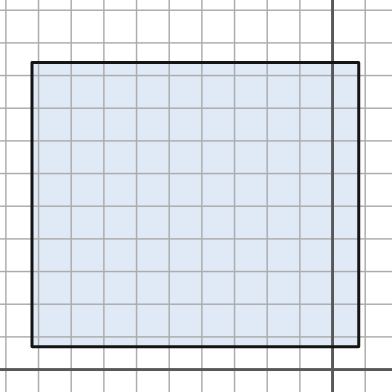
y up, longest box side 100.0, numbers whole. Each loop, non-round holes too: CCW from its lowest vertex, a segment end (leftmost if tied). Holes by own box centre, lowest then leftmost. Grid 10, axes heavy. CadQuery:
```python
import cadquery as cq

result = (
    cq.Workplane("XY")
    .moveTo(-92.0, 7.0)
    .lineTo(8.0, 7.0)
    .lineTo(8.0, 94.0)
    .lineTo(-92.0, 94.0)
    .close()
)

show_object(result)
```